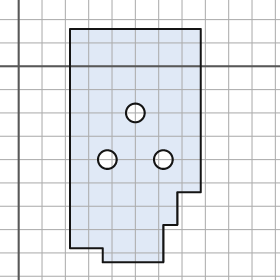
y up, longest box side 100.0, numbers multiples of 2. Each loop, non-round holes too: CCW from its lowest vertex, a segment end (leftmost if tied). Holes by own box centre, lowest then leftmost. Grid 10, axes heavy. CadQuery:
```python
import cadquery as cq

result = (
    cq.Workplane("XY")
    .moveTo(36.0, -84.0)
    .lineTo(62.0, -84.0)
    .lineTo(62.0, -68.0)
    .lineTo(68.0, -68.0)
    .lineTo(68.0, -54.0)
    .lineTo(78.0, -54.0)
    .lineTo(78.0, 16.0)
    .lineTo(22.0, 16.0)
    .lineTo(22.0, -78.0)
    .lineTo(36.0, -78.0)
    .close()
    .moveTo(38.0, -40.0)
    .circle(4.0)
    .moveTo(62.0, -40.0)
    .circle(4.0)
    .moveTo(50.0, -20.0)
    .circle(4.0)
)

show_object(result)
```